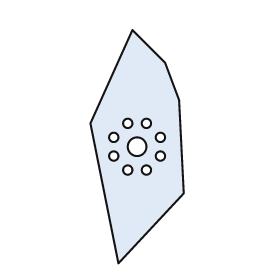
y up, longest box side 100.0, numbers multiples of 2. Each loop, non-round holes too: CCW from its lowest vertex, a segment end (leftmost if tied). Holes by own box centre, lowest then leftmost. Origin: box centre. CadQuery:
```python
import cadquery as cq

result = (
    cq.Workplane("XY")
    .moveTo(-8.0, -50.0)
    .lineTo(20.0, -20.0)
    .lineTo(18.0, 20.0)
    .lineTo(12.0, 36.0)
    .lineTo(-2.0, 50.0)
    .lineTo(-20.0, 10.0)
    .close()
    .moveTo(-4.0, -10.0)
    .circle(2.0)
    .moveTo(4.0, -10.0)
    .circle(2.0)
    .moveTo(-10.0, -4.0)
    .circle(2.0)
    .moveTo(10.0, -4.0)
    .circle(2.0)
    .moveTo(0.0, 0.0)
    .circle(4.0)
    .moveTo(-10.0, 4.0)
    .circle(2.0)
    .moveTo(10.0, 4.0)
    .circle(2.0)
    .moveTo(-4.0, 10.0)
    .circle(2.0)
    .moveTo(4.0, 10.0)
    .circle(2.0)
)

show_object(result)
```